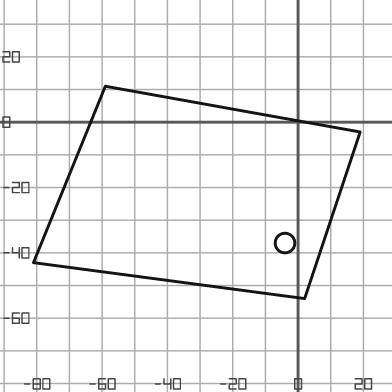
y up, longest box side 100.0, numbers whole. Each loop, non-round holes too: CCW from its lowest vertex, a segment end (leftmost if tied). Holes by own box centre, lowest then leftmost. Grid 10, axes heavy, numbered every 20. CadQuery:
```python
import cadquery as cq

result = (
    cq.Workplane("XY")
    .moveTo(2.0, -54.0)
    .lineTo(19.0, -3.0)
    .lineTo(-59.0, 11.0)
    .lineTo(-81.0, -43.0)
    .close()
    .moveTo(-4.0, -37.0)
    .circle(3.0)
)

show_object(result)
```